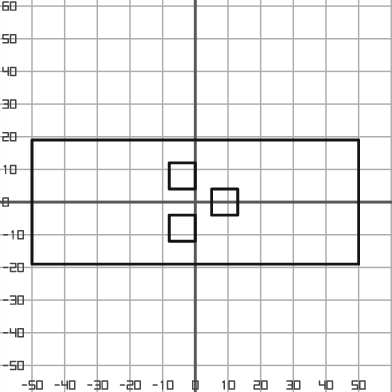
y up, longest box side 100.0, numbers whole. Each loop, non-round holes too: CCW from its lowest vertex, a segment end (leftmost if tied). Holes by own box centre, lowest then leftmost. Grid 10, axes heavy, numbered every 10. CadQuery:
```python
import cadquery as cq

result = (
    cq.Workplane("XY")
    .moveTo(-50.0, -19.0)
    .lineTo(50.0, -19.0)
    .lineTo(50.0, 19.0)
    .lineTo(-50.0, 19.0)
    .close()
    .moveTo(-8.0, -12.0)
    .lineTo(0.0, -12.0)
    .lineTo(0.0, -4.0)
    .lineTo(-8.0, -4.0)
    .close()
    .moveTo(5.0, -4.0)
    .lineTo(13.0, -4.0)
    .lineTo(13.0, 4.0)
    .lineTo(5.0, 4.0)
    .close()
    .moveTo(-8.0, 4.0)
    .lineTo(0.0, 4.0)
    .lineTo(0.0, 12.0)
    .lineTo(-8.0, 12.0)
    .close()
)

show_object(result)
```